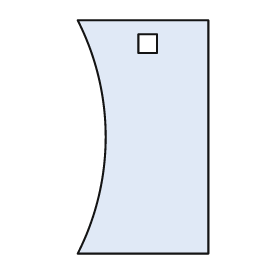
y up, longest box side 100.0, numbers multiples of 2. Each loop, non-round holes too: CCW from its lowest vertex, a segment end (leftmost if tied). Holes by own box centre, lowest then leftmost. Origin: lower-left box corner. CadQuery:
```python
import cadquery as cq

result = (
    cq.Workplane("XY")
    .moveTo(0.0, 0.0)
    .lineTo(56.0, 0.0)
    .lineTo(56.0, 100.0)
    .lineTo(0.0, 100.0)
    .threePointArc((12.0, 50.0), (0.0, 0.0))
    .close()
    .moveTo(26.0, 86.0)
    .lineTo(34.0, 86.0)
    .lineTo(34.0, 94.0)
    .lineTo(26.0, 94.0)
    .close()
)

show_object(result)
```